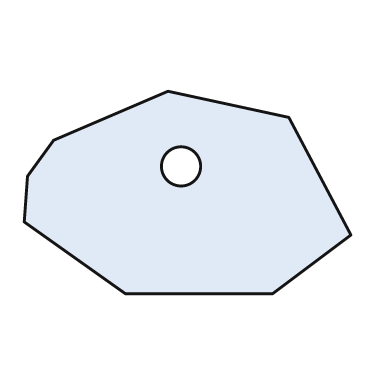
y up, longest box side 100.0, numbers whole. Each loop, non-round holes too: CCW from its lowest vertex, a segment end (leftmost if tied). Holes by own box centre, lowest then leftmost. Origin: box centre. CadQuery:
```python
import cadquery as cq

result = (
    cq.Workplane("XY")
    .moveTo(-19.0, -31.0)
    .lineTo(26.0, -31.0)
    .lineTo(50.0, -13.0)
    .lineTo(31.0, 23.0)
    .lineTo(-6.0, 31.0)
    .lineTo(-41.0, 16.0)
    .lineTo(-49.0, 5.0)
    .lineTo(-50.0, -9.0)
    .close()
    .moveTo(-2.0, 8.0)
    .circle(6.0)
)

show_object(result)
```